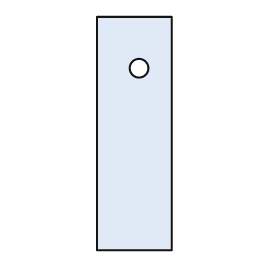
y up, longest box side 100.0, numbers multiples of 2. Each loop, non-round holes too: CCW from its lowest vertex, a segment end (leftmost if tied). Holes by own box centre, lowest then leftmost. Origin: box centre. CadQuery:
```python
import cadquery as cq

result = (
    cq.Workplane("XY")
    .moveTo(-16.0, -50.0)
    .lineTo(16.0, -50.0)
    .lineTo(16.0, 50.0)
    .lineTo(-16.0, 50.0)
    .close()
    .moveTo(2.0, 28.0)
    .circle(4.0)
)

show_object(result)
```